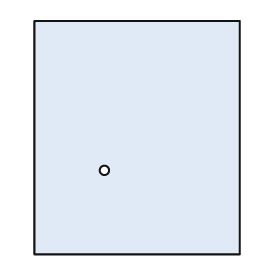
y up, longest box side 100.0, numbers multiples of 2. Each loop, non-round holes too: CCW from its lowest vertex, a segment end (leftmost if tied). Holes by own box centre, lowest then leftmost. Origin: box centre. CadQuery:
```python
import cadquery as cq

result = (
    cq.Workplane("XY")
    .moveTo(-44.0, -50.0)
    .lineTo(44.0, -50.0)
    .lineTo(44.0, 50.0)
    .lineTo(-44.0, 50.0)
    .close()
    .moveTo(-14.0, -14.0)
    .circle(2.0)
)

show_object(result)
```